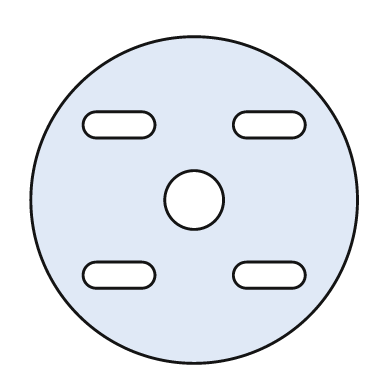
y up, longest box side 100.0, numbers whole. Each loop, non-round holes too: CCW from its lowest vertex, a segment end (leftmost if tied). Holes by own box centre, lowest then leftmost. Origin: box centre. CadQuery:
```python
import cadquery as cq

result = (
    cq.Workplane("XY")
    .moveTo(0.0, 0.0)
    .circle(50.0)
    .moveTo(-30.0, -27.0)
    .lineTo(-16.0, -27.0)
    .threePointArc((-12.0, -23.0), (-16.0, -19.0))
    .lineTo(-30.0, -19.0)
    .threePointArc((-34.0, -23.0), (-30.0, -27.0))
    .close()
    .moveTo(16.0, -27.0)
    .lineTo(30.0, -27.0)
    .threePointArc((34.0, -23.0), (30.0, -19.0))
    .lineTo(16.0, -19.0)
    .threePointArc((12.0, -23.0), (16.0, -27.0))
    .close()
    .moveTo(0.0, 0.0)
    .circle(9.0)
    .moveTo(-30.0, 19.0)
    .lineTo(-16.0, 19.0)
    .threePointArc((-12.0, 23.0), (-16.0, 27.0))
    .lineTo(-30.0, 27.0)
    .threePointArc((-34.0, 23.0), (-30.0, 19.0))
    .close()
    .moveTo(16.0, 19.0)
    .lineTo(30.0, 19.0)
    .threePointArc((34.0, 23.0), (30.0, 27.0))
    .lineTo(16.0, 27.0)
    .threePointArc((12.0, 23.0), (16.0, 19.0))
    .close()
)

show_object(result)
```